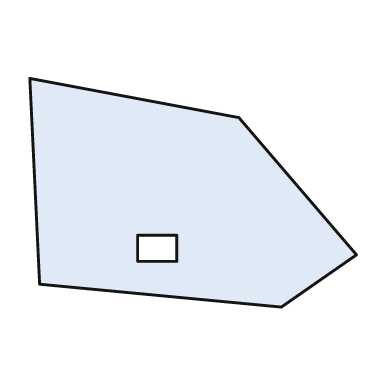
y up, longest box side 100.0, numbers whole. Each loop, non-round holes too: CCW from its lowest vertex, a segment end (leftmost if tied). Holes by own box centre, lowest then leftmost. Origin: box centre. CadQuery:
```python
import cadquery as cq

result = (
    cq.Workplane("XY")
    .moveTo(27.0, -35.0)
    .lineTo(50.0, -19.0)
    .lineTo(14.0, 23.0)
    .lineTo(-50.0, 35.0)
    .lineTo(-47.0, -28.0)
    .close()
    .moveTo(-17.0, -21.0)
    .lineTo(-5.0, -21.0)
    .lineTo(-5.0, -13.0)
    .lineTo(-17.0, -13.0)
    .close()
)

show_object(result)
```